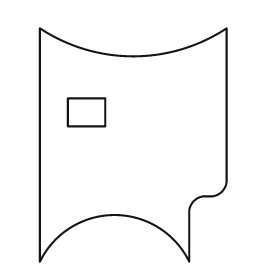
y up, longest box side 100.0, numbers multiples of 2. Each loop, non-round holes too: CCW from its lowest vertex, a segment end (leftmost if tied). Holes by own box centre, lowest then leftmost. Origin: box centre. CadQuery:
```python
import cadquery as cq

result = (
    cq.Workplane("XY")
    .moveTo(-40.0, -50.0)
    .threePointArc((-8.0, -30.0), (24.0, -50.0))
    .lineTo(24.0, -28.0)
    .threePointArc((26.0, -24.0), (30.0, -22.0))
    .lineTo(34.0, -22.0)
    .threePointArc((38.0, -20.0), (40.0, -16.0))
    .lineTo(40.0, 50.0)
    .threePointArc((0.0, 38.0), (-40.0, 50.0))
    .close()
    .moveTo(-28.0, 8.0)
    .lineTo(-12.0, 8.0)
    .lineTo(-12.0, 20.0)
    .lineTo(-28.0, 20.0)
    .close()
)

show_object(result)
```